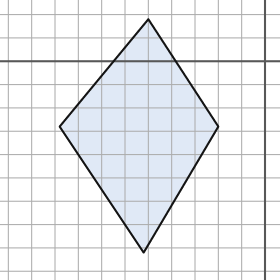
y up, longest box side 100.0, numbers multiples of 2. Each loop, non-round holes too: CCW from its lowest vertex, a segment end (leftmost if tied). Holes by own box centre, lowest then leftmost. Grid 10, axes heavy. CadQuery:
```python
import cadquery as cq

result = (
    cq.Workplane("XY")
    .moveTo(-52.0, -82.0)
    .lineTo(-20.0, -28.0)
    .lineTo(-50.0, 18.0)
    .lineTo(-88.0, -28.0)
    .close()
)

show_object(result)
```